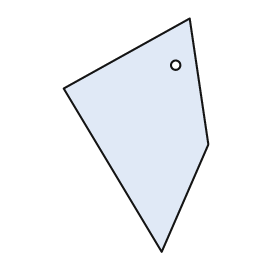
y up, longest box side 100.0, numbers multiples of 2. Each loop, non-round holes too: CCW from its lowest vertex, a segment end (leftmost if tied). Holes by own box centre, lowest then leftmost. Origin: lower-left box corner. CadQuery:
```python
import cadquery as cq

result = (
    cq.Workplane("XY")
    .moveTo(42.0, 0.0)
    .lineTo(62.0, 46.0)
    .lineTo(54.0, 100.0)
    .lineTo(0.0, 70.0)
    .close()
    .moveTo(48.0, 80.0)
    .circle(2.0)
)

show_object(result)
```